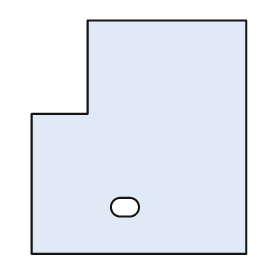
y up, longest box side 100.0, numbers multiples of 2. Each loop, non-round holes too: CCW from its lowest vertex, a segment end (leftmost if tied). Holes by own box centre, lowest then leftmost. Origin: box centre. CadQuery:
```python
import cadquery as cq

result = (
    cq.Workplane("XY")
    .moveTo(-46.0, -50.0)
    .lineTo(46.0, -50.0)
    .lineTo(46.0, 50.0)
    .lineTo(-22.0, 50.0)
    .lineTo(-22.0, 10.0)
    .lineTo(-46.0, 10.0)
    .close()
    .moveTo(-8.0, -34.0)
    .lineTo(-4.0, -34.0)
    .threePointArc((0.0, -30.0), (-4.0, -26.0))
    .lineTo(-8.0, -26.0)
    .threePointArc((-12.0, -30.0), (-8.0, -34.0))
    .close()
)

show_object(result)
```